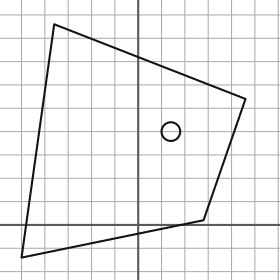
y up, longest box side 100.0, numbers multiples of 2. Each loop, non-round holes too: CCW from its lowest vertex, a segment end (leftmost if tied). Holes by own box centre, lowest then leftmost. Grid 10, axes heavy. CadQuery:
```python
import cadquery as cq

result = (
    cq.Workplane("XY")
    .moveTo(-50.0, -14.0)
    .lineTo(28.0, 2.0)
    .lineTo(46.0, 54.0)
    .lineTo(-36.0, 86.0)
    .close()
    .moveTo(14.0, 40.0)
    .circle(4.0)
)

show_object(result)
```